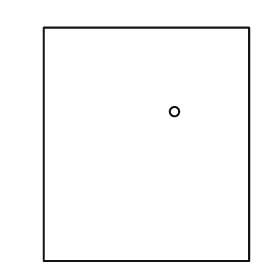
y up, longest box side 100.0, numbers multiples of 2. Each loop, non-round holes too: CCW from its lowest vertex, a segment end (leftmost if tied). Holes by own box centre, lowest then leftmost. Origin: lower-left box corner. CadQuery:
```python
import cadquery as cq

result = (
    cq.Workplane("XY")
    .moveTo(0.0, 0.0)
    .lineTo(88.0, 0.0)
    .lineTo(88.0, 100.0)
    .lineTo(0.0, 100.0)
    .close()
    .moveTo(56.0, 64.0)
    .circle(2.0)
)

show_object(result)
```